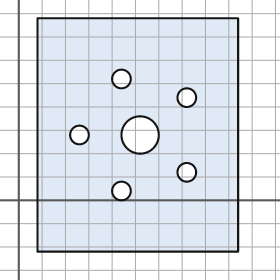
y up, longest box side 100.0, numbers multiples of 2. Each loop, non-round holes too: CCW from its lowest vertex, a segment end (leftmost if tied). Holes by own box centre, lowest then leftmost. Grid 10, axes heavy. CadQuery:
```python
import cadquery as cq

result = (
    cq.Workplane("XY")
    .moveTo(8.0, -22.0)
    .lineTo(94.0, -22.0)
    .lineTo(94.0, 78.0)
    .lineTo(8.0, 78.0)
    .close()
    .moveTo(44.0, 4.0)
    .circle(4.0)
    .moveTo(72.0, 12.0)
    .circle(4.0)
    .moveTo(26.0, 28.0)
    .circle(4.0)
    .moveTo(52.0, 28.0)
    .circle(8.0)
    .moveTo(72.0, 44.0)
    .circle(4.0)
    .moveTo(44.0, 52.0)
    .circle(4.0)
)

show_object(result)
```